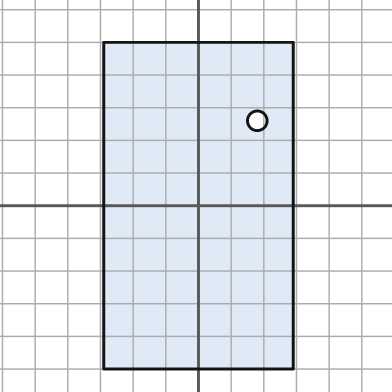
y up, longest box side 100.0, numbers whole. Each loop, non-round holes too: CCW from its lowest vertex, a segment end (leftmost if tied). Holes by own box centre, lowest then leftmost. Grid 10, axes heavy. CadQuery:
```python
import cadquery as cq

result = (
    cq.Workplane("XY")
    .moveTo(-29.0, -50.0)
    .lineTo(29.0, -50.0)
    .lineTo(29.0, 50.0)
    .lineTo(-29.0, 50.0)
    .close()
    .moveTo(18.0, 26.0)
    .circle(3.0)
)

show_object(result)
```